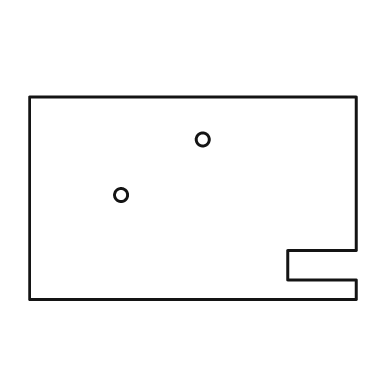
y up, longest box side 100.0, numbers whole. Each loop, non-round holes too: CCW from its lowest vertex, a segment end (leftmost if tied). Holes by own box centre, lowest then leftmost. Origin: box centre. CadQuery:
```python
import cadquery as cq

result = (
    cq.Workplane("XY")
    .moveTo(-50.0, -31.0)
    .lineTo(50.0, -31.0)
    .lineTo(50.0, -25.0)
    .lineTo(29.0, -25.0)
    .lineTo(29.0, -16.0)
    .lineTo(50.0, -16.0)
    .lineTo(50.0, 31.0)
    .lineTo(-50.0, 31.0)
    .close()
    .moveTo(-22.0, 1.0)
    .circle(2.0)
    .moveTo(3.0, 18.0)
    .circle(2.0)
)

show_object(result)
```